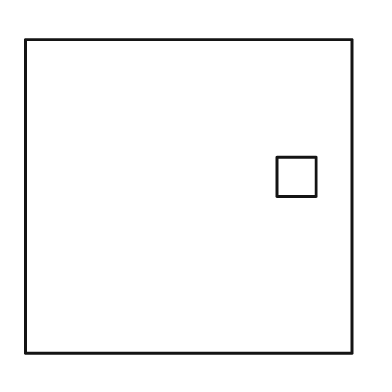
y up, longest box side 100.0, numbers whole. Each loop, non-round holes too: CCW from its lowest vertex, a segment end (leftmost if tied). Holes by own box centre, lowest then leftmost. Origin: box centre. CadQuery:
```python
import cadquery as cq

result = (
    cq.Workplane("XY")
    .moveTo(-50.0, -48.0)
    .lineTo(50.0, -48.0)
    .lineTo(50.0, 48.0)
    .lineTo(-50.0, 48.0)
    .close()
    .moveTo(27.0, 0.0)
    .lineTo(39.0, 0.0)
    .lineTo(39.0, 12.0)
    .lineTo(27.0, 12.0)
    .close()
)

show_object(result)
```